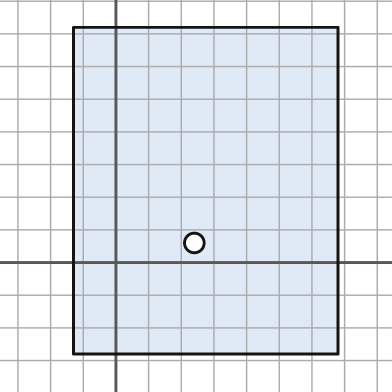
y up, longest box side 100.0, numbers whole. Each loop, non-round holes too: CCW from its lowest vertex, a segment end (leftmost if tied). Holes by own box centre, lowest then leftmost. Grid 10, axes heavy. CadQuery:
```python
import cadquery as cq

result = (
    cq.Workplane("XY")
    .moveTo(-13.0, -28.0)
    .lineTo(68.0, -28.0)
    .lineTo(68.0, 72.0)
    .lineTo(-13.0, 72.0)
    .close()
    .moveTo(24.0, 6.0)
    .circle(3.0)
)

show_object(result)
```